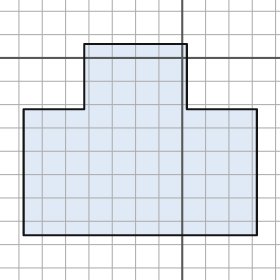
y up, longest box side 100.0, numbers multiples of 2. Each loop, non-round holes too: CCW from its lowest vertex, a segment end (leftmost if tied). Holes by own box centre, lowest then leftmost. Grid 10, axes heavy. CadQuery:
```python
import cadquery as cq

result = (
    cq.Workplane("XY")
    .moveTo(-68.0, -76.0)
    .lineTo(32.0, -76.0)
    .lineTo(32.0, -22.0)
    .lineTo(2.0, -22.0)
    .lineTo(2.0, 6.0)
    .lineTo(-42.0, 6.0)
    .lineTo(-42.0, -22.0)
    .lineTo(-68.0, -22.0)
    .close()
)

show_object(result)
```